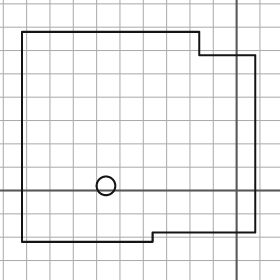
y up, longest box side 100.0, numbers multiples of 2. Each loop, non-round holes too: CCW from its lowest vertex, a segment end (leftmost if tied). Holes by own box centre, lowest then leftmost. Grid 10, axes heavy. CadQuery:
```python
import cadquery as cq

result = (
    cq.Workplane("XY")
    .moveTo(-92.0, -22.0)
    .lineTo(-36.0, -22.0)
    .lineTo(-36.0, -18.0)
    .lineTo(8.0, -18.0)
    .lineTo(8.0, 58.0)
    .lineTo(-16.0, 58.0)
    .lineTo(-16.0, 68.0)
    .lineTo(-92.0, 68.0)
    .close()
    .moveTo(-56.0, 2.0)
    .circle(4.0)
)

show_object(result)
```